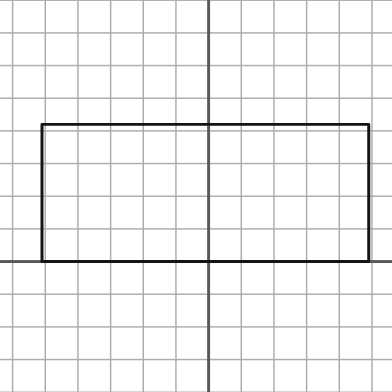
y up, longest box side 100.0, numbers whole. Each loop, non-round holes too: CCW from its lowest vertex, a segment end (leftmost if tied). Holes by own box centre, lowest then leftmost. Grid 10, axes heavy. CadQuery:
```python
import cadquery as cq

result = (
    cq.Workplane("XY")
    .moveTo(-51.0, 0.0)
    .lineTo(49.0, 0.0)
    .lineTo(49.0, 42.0)
    .lineTo(-51.0, 42.0)
    .close()
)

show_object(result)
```